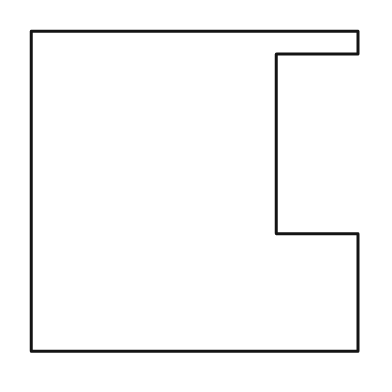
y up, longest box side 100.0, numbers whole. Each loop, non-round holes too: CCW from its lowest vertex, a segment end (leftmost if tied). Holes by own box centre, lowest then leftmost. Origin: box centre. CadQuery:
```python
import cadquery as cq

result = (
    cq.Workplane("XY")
    .moveTo(-50.0, -49.0)
    .lineTo(50.0, -49.0)
    .lineTo(50.0, -13.0)
    .lineTo(25.0, -13.0)
    .lineTo(25.0, 42.0)
    .lineTo(50.0, 42.0)
    .lineTo(50.0, 49.0)
    .lineTo(-50.0, 49.0)
    .close()
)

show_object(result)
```